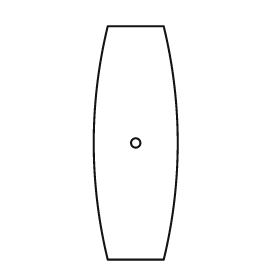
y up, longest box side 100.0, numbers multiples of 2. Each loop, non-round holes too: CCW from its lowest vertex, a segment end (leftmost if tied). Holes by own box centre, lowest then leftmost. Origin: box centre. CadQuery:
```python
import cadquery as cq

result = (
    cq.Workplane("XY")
    .moveTo(-12.0, -50.0)
    .lineTo(12.0, -50.0)
    .threePointArc((18.0, 0.0), (12.0, 50.0))
    .lineTo(-12.0, 50.0)
    .threePointArc((-18.0, 0.0), (-12.0, -50.0))
    .close()
    .moveTo(0.0, 0.0)
    .circle(2.0)
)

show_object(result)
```